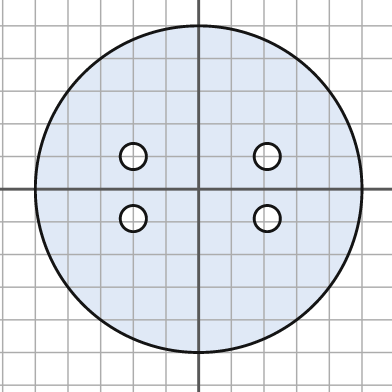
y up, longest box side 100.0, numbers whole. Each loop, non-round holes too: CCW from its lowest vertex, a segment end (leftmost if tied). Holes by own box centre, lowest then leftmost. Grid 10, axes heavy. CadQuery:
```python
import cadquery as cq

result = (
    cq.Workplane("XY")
    .moveTo(0.0, 0.0)
    .circle(50.0)
    .moveTo(-20.0, -9.0)
    .circle(4.0)
    .moveTo(21.0, -9.0)
    .circle(4.0)
    .moveTo(-20.0, 10.0)
    .circle(4.0)
    .moveTo(21.0, 10.0)
    .circle(4.0)
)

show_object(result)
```